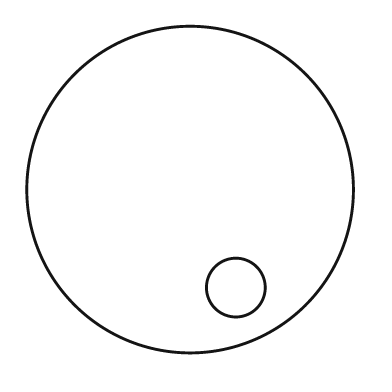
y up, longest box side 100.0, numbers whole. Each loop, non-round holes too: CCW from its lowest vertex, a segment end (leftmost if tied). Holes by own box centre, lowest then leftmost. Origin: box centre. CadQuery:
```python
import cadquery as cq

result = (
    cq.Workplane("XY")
    .moveTo(0.0, 0.0)
    .circle(50.0)
    .moveTo(14.0, -30.0)
    .circle(9.0)
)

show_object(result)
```